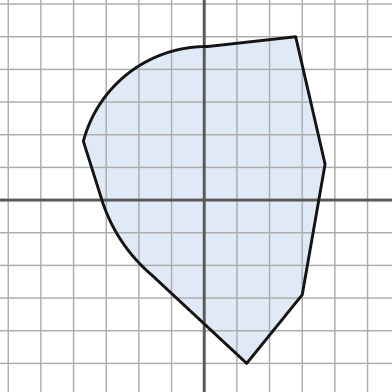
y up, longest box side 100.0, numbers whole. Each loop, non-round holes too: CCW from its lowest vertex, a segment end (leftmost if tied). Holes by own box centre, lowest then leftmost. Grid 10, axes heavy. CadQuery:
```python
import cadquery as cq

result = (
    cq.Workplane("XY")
    .moveTo(13.0, -50.0)
    .lineTo(30.0, -29.0)
    .lineTo(37.0, 11.0)
    .lineTo(28.0, 50.0)
    .lineTo(1.0, 47.0)
    .threePointArc((-23.0, 39.0), (-37.0, 18.0))
    .lineTo(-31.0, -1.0)
    .threePointArc((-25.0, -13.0), (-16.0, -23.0))
    .close()
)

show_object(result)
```